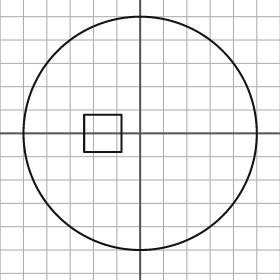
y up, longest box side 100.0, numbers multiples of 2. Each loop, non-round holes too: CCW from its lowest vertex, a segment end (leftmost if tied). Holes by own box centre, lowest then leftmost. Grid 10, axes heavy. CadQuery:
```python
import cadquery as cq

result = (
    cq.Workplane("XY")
    .moveTo(0.0, 0.0)
    .circle(50.0)
    .moveTo(-24.0, -8.0)
    .lineTo(-8.0, -8.0)
    .lineTo(-8.0, 8.0)
    .lineTo(-24.0, 8.0)
    .close()
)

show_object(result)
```